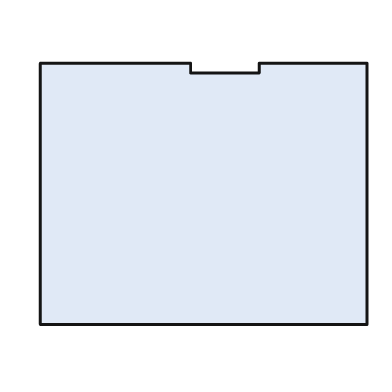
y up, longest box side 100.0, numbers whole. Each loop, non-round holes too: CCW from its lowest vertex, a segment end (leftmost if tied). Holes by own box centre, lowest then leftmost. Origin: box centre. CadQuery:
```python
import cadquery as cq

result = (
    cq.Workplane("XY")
    .moveTo(-50.0, -40.0)
    .lineTo(50.0, -40.0)
    .lineTo(50.0, 40.0)
    .lineTo(17.0, 40.0)
    .lineTo(17.0, 37.0)
    .lineTo(-4.0, 37.0)
    .lineTo(-4.0, 40.0)
    .lineTo(-50.0, 40.0)
    .close()
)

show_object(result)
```